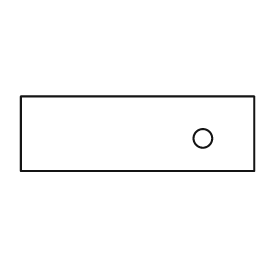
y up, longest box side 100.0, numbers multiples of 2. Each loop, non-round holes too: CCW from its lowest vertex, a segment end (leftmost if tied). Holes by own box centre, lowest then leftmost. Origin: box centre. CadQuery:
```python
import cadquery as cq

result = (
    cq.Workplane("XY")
    .moveTo(-50.0, -16.0)
    .lineTo(50.0, -16.0)
    .lineTo(50.0, 16.0)
    .lineTo(-50.0, 16.0)
    .close()
    .moveTo(28.0, -2.0)
    .circle(4.0)
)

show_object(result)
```